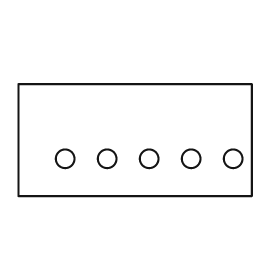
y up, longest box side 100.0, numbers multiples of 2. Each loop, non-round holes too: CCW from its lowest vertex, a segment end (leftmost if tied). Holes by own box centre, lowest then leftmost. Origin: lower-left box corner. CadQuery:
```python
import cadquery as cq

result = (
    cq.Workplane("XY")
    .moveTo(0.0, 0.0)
    .lineTo(100.0, 0.0)
    .lineTo(100.0, 48.0)
    .lineTo(0.0, 48.0)
    .close()
    .moveTo(20.0, 16.0)
    .circle(4.0)
    .moveTo(38.0, 16.0)
    .circle(4.0)
    .moveTo(56.0, 16.0)
    .circle(4.0)
    .moveTo(74.0, 16.0)
    .circle(4.0)
    .moveTo(92.0, 16.0)
    .circle(4.0)
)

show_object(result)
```